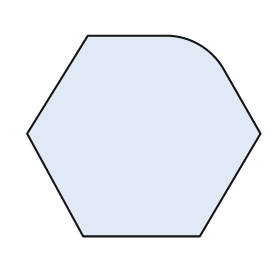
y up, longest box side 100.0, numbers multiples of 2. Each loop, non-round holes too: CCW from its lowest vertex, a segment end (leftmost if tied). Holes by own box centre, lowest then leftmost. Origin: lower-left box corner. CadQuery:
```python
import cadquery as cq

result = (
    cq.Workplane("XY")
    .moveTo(24.0, 0.0)
    .lineTo(74.0, 0.0)
    .lineTo(100.0, 44.0)
    .lineTo(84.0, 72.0)
    .threePointArc((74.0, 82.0), (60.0, 86.0))
    .lineTo(26.0, 86.0)
    .lineTo(0.0, 44.0)
    .close()
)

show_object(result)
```